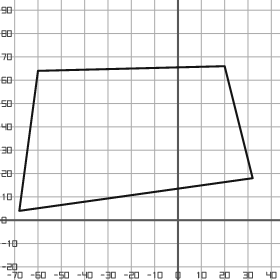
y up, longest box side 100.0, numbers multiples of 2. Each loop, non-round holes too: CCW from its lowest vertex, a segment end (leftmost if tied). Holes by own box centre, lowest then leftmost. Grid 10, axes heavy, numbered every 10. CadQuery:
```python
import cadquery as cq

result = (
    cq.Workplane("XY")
    .moveTo(-68.0, 4.0)
    .lineTo(32.0, 18.0)
    .lineTo(20.0, 66.0)
    .lineTo(-60.0, 64.0)
    .close()
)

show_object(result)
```